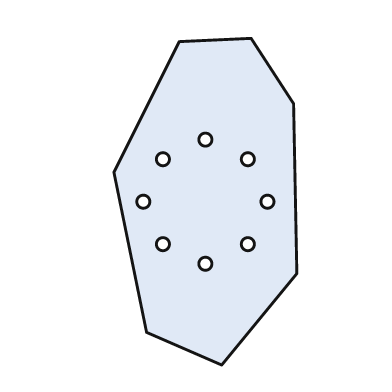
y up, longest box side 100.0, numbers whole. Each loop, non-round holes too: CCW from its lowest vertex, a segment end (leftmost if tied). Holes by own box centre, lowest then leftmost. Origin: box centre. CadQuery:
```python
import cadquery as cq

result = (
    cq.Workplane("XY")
    .moveTo(5.0, -50.0)
    .lineTo(28.0, -22.0)
    .lineTo(27.0, 30.0)
    .lineTo(14.0, 50.0)
    .lineTo(-8.0, 49.0)
    .lineTo(-28.0, 9.0)
    .lineTo(-18.0, -40.0)
    .close()
    .moveTo(0.0, -19.0)
    .circle(2.0)
    .moveTo(-13.0, -13.0)
    .circle(2.0)
    .moveTo(13.0, -13.0)
    .circle(2.0)
    .moveTo(-19.0, 0.0)
    .circle(2.0)
    .moveTo(19.0, 0.0)
    .circle(2.0)
    .moveTo(-13.0, 13.0)
    .circle(2.0)
    .moveTo(13.0, 13.0)
    .circle(2.0)
    .moveTo(0.0, 19.0)
    .circle(2.0)
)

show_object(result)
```